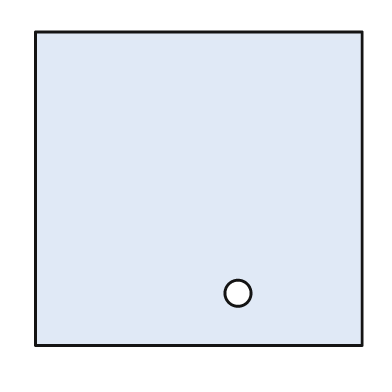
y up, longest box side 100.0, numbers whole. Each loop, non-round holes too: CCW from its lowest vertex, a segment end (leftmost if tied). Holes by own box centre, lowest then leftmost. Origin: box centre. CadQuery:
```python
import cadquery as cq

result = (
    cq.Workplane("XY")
    .moveTo(-50.0, -48.0)
    .lineTo(50.0, -48.0)
    .lineTo(50.0, 48.0)
    .lineTo(-50.0, 48.0)
    .close()
    .moveTo(12.0, -32.0)
    .circle(4.0)
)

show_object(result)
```